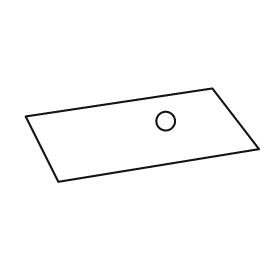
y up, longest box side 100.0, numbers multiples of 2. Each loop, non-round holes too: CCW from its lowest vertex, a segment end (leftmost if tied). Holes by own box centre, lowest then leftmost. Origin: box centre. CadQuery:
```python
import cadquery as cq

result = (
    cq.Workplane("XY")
    .moveTo(-36.0, -20.0)
    .lineTo(50.0, -6.0)
    .lineTo(30.0, 20.0)
    .lineTo(-50.0, 8.0)
    .close()
    .moveTo(10.0, 6.0)
    .circle(4.0)
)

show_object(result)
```